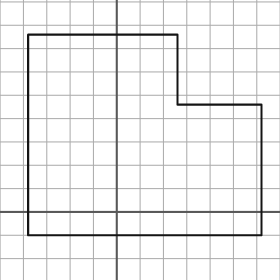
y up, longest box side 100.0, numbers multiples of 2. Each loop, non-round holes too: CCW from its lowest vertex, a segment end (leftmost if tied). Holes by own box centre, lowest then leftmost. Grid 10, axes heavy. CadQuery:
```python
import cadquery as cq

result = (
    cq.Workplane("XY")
    .moveTo(-38.0, -10.0)
    .lineTo(62.0, -10.0)
    .lineTo(62.0, 46.0)
    .lineTo(26.0, 46.0)
    .lineTo(26.0, 76.0)
    .lineTo(-38.0, 76.0)
    .close()
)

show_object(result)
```